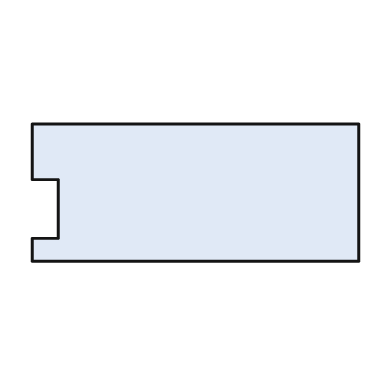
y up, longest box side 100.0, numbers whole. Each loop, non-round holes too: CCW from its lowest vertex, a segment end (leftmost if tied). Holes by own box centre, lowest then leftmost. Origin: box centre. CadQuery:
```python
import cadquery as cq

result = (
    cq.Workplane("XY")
    .moveTo(-50.0, -21.0)
    .lineTo(50.0, -21.0)
    .lineTo(50.0, 21.0)
    .lineTo(-50.0, 21.0)
    .lineTo(-50.0, 4.0)
    .lineTo(-42.0, 4.0)
    .lineTo(-42.0, -14.0)
    .lineTo(-50.0, -14.0)
    .close()
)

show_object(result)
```